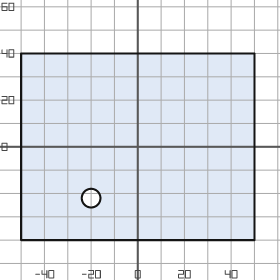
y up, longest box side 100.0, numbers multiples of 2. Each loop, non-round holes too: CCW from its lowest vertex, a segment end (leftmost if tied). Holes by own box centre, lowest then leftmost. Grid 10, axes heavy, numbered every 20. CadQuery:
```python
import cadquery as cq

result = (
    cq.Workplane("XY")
    .moveTo(-50.0, -40.0)
    .lineTo(50.0, -40.0)
    .lineTo(50.0, 40.0)
    .lineTo(-50.0, 40.0)
    .close()
    .moveTo(-20.0, -22.0)
    .circle(4.0)
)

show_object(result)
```